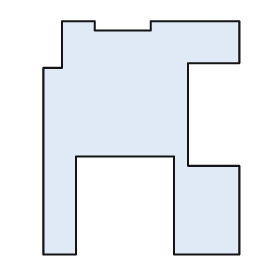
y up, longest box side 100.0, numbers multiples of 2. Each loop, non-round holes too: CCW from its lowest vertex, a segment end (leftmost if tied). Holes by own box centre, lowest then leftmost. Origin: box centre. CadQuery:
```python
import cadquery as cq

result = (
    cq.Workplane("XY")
    .moveTo(-42.0, -50.0)
    .lineTo(-28.0, -50.0)
    .lineTo(-28.0, -8.0)
    .lineTo(14.0, -8.0)
    .lineTo(14.0, -50.0)
    .lineTo(42.0, -50.0)
    .lineTo(42.0, -12.0)
    .lineTo(20.0, -12.0)
    .lineTo(20.0, 32.0)
    .lineTo(42.0, 32.0)
    .lineTo(42.0, 50.0)
    .lineTo(4.0, 50.0)
    .lineTo(4.0, 46.0)
    .lineTo(-20.0, 46.0)
    .lineTo(-20.0, 50.0)
    .lineTo(-34.0, 50.0)
    .lineTo(-34.0, 30.0)
    .lineTo(-42.0, 30.0)
    .close()
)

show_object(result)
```